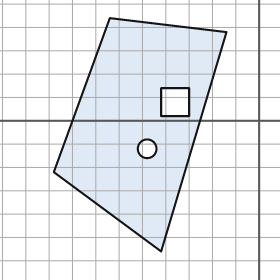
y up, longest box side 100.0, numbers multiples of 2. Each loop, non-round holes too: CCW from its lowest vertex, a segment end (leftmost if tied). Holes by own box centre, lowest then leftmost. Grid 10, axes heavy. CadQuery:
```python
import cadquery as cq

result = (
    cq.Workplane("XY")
    .moveTo(-42.0, -56.0)
    .lineTo(-14.0, 38.0)
    .lineTo(-64.0, 44.0)
    .lineTo(-88.0, -22.0)
    .close()
    .moveTo(-48.0, -12.0)
    .circle(4.0)
    .moveTo(-42.0, 2.0)
    .lineTo(-30.0, 2.0)
    .lineTo(-30.0, 14.0)
    .lineTo(-42.0, 14.0)
    .close()
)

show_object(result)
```